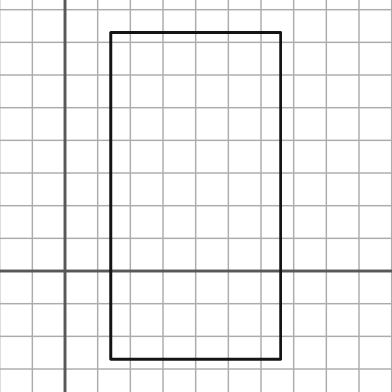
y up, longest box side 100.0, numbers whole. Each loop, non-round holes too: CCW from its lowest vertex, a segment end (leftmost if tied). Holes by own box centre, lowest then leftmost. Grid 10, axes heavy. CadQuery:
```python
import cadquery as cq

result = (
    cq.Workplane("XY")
    .moveTo(14.0, -27.0)
    .lineTo(66.0, -27.0)
    .lineTo(66.0, 73.0)
    .lineTo(14.0, 73.0)
    .close()
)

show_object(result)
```